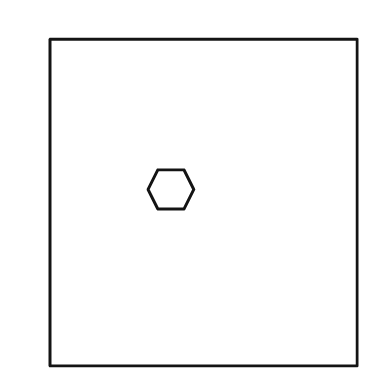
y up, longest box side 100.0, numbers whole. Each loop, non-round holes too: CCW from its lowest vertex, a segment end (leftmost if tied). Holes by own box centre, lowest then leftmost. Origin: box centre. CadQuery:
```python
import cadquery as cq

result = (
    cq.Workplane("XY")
    .moveTo(-47.0, -50.0)
    .lineTo(47.0, -50.0)
    .lineTo(47.0, 50.0)
    .lineTo(-47.0, 50.0)
    .close()
    .moveTo(-14.0, -2.0)
    .lineTo(-6.0, -2.0)
    .lineTo(-3.0, 4.0)
    .lineTo(-6.0, 10.0)
    .lineTo(-14.0, 10.0)
    .lineTo(-17.0, 4.0)
    .close()
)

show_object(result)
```